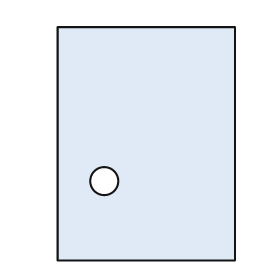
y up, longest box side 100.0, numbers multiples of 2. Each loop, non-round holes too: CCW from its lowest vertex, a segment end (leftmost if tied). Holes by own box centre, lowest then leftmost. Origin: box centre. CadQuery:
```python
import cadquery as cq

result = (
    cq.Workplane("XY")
    .moveTo(-38.0, -50.0)
    .lineTo(38.0, -50.0)
    .lineTo(38.0, 50.0)
    .lineTo(-38.0, 50.0)
    .close()
    .moveTo(-18.0, -16.0)
    .circle(6.0)
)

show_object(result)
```